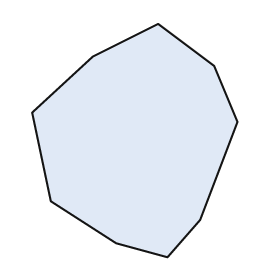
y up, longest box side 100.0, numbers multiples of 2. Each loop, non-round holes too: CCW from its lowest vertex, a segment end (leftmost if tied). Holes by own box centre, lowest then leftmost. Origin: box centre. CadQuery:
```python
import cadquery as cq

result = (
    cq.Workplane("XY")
    .moveTo(14.0, -50.0)
    .lineTo(28.0, -34.0)
    .lineTo(44.0, 8.0)
    .lineTo(34.0, 32.0)
    .lineTo(10.0, 50.0)
    .lineTo(-18.0, 36.0)
    .lineTo(-44.0, 12.0)
    .lineTo(-36.0, -26.0)
    .lineTo(-8.0, -44.0)
    .close()
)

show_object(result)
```